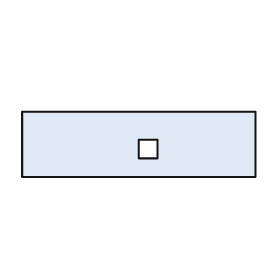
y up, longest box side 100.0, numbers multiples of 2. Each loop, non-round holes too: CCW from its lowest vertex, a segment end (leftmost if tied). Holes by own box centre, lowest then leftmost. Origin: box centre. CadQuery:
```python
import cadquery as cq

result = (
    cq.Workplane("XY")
    .moveTo(-50.0, -14.0)
    .lineTo(50.0, -14.0)
    .lineTo(50.0, 14.0)
    .lineTo(-50.0, 14.0)
    .close()
    .moveTo(0.0, -6.0)
    .lineTo(8.0, -6.0)
    .lineTo(8.0, 2.0)
    .lineTo(0.0, 2.0)
    .close()
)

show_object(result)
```